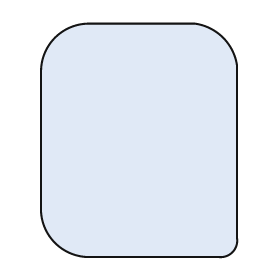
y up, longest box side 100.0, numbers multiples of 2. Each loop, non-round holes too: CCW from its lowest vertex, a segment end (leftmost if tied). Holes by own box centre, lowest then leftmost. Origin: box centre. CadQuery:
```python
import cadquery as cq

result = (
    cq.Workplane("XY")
    .moveTo(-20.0, -50.0)
    .lineTo(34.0, -50.0)
    .threePointArc((40.0, -48.0), (42.0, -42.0))
    .lineTo(42.0, 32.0)
    .threePointArc((36.0, 44.0), (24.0, 50.0))
    .lineTo(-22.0, 50.0)
    .threePointArc((-36.0, 44.0), (-42.0, 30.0))
    .lineTo(-42.0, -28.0)
    .threePointArc((-36.0, -44.0), (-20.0, -50.0))
    .close()
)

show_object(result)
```